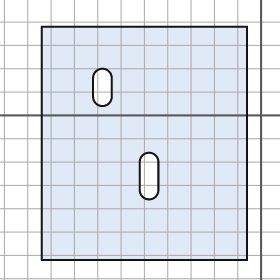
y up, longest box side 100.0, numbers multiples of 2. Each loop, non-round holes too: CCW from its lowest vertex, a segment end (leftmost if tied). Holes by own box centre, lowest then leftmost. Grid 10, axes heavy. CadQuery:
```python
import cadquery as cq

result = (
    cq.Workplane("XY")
    .moveTo(-94.0, -62.0)
    .lineTo(-6.0, -62.0)
    .lineTo(-6.0, 38.0)
    .lineTo(-94.0, 38.0)
    .close()
    .moveTo(-52.0, -32.0)
    .threePointArc((-48.0, -36.0), (-44.0, -32.0))
    .lineTo(-44.0, -20.0)
    .threePointArc((-48.0, -16.0), (-52.0, -20.0))
    .close()
    .moveTo(-72.0, 8.0)
    .threePointArc((-68.0, 4.0), (-64.0, 8.0))
    .lineTo(-64.0, 16.0)
    .threePointArc((-68.0, 20.0), (-72.0, 16.0))
    .close()
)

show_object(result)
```